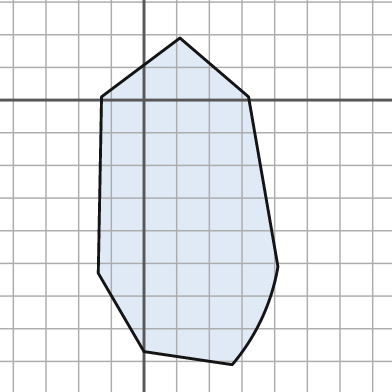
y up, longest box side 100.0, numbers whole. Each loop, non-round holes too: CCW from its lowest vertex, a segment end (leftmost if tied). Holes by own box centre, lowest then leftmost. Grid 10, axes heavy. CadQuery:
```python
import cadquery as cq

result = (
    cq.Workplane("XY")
    .moveTo(27.0, -81.0)
    .threePointArc((36.0, -67.0), (41.0, -51.0))
    .lineTo(32.0, 1.0)
    .lineTo(11.0, 19.0)
    .lineTo(-13.0, 1.0)
    .lineTo(-14.0, -53.0)
    .lineTo(0.0, -77.0)
    .close()
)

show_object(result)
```